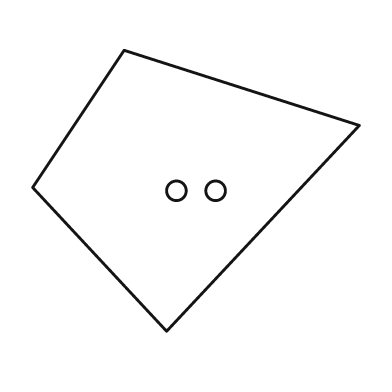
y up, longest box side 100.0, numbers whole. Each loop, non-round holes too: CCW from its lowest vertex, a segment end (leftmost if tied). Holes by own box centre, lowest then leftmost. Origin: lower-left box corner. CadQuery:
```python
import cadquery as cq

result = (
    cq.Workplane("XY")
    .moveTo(41.0, 0.0)
    .lineTo(100.0, 63.0)
    .lineTo(28.0, 86.0)
    .lineTo(0.0, 44.0)
    .close()
    .moveTo(44.0, 43.0)
    .circle(3.0)
    .moveTo(56.0, 43.0)
    .circle(3.0)
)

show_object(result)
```